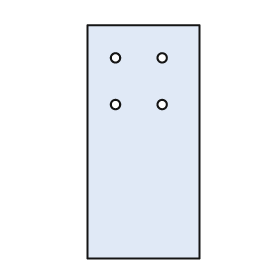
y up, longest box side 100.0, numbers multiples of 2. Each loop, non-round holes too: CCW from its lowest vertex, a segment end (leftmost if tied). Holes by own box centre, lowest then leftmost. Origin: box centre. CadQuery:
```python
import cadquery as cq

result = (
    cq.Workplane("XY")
    .moveTo(-24.0, -50.0)
    .lineTo(24.0, -50.0)
    .lineTo(24.0, 50.0)
    .lineTo(-24.0, 50.0)
    .close()
    .moveTo(-12.0, 16.0)
    .circle(2.0)
    .moveTo(8.0, 16.0)
    .circle(2.0)
    .moveTo(-12.0, 36.0)
    .circle(2.0)
    .moveTo(8.0, 36.0)
    .circle(2.0)
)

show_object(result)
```